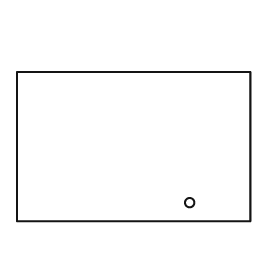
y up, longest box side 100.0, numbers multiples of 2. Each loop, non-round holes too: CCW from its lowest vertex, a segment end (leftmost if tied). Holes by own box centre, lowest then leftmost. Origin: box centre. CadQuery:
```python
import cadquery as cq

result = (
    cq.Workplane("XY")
    .moveTo(-50.0, -32.0)
    .lineTo(50.0, -32.0)
    .lineTo(50.0, 32.0)
    .lineTo(-50.0, 32.0)
    .close()
    .moveTo(24.0, -24.0)
    .circle(2.0)
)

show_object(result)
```